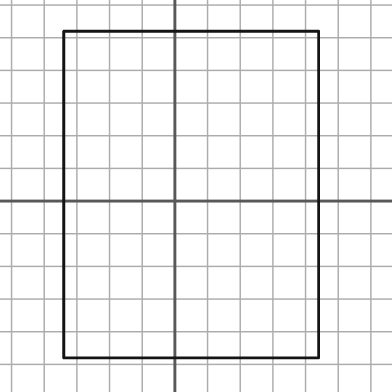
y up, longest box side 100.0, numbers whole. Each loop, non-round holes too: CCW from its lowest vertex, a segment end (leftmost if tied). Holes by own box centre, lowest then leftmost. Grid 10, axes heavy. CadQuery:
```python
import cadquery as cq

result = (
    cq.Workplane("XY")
    .moveTo(-34.0, -48.0)
    .lineTo(44.0, -48.0)
    .lineTo(44.0, 52.0)
    .lineTo(-34.0, 52.0)
    .close()
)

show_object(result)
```